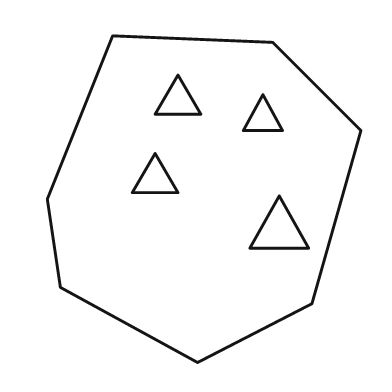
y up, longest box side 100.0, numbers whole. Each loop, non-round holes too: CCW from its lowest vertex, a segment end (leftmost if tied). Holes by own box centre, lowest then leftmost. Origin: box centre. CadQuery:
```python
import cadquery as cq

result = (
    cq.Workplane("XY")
    .moveTo(-2.0, -50.0)
    .lineTo(33.0, -32.0)
    .lineTo(48.0, 21.0)
    .lineTo(21.0, 48.0)
    .lineTo(-28.0, 50.0)
    .lineTo(-48.0, 0.0)
    .lineTo(-44.0, -27.0)
    .close()
    .moveTo(14.0, -15.0)
    .lineTo(32.0, -15.0)
    .lineTo(23.0, 1.0)
    .close()
    .moveTo(-22.0, 2.0)
    .lineTo(-8.0, 2.0)
    .lineTo(-15.0, 14.0)
    .close()
    .moveTo(12.0, 21.0)
    .lineTo(24.0, 21.0)
    .lineTo(18.0, 32.0)
    .close()
    .moveTo(-15.0, 26.0)
    .lineTo(-1.0, 26.0)
    .lineTo(-8.0, 38.0)
    .close()
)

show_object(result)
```